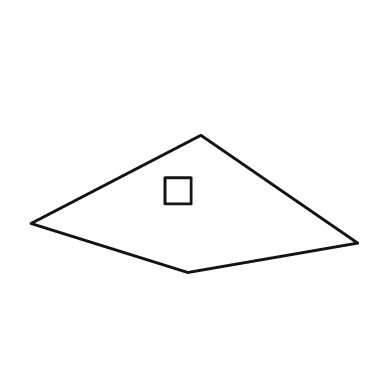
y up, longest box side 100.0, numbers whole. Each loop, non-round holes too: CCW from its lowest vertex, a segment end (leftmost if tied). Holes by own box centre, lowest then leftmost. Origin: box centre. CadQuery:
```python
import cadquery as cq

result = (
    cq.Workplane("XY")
    .moveTo(-2.0, -21.0)
    .lineTo(50.0, -12.0)
    .lineTo(2.0, 21.0)
    .lineTo(-50.0, -6.0)
    .close()
    .moveTo(-9.0, 0.0)
    .lineTo(-1.0, 0.0)
    .lineTo(-1.0, 8.0)
    .lineTo(-9.0, 8.0)
    .close()
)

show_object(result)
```